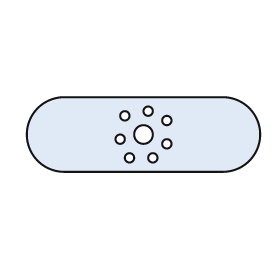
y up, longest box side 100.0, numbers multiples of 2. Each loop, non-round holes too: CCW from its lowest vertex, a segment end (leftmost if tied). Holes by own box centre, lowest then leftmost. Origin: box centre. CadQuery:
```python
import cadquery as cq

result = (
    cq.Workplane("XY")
    .moveTo(-34.0, -16.0)
    .lineTo(34.0, -16.0)
    .threePointArc((50.0, 0.0), (34.0, 16.0))
    .lineTo(-34.0, 16.0)
    .threePointArc((-50.0, 0.0), (-34.0, -16.0))
    .close()
    .moveTo(-6.0, -10.0)
    .circle(2.0)
    .moveTo(4.0, -10.0)
    .circle(2.0)
    .moveTo(10.0, -4.0)
    .circle(2.0)
    .moveTo(-10.0, -2.0)
    .circle(2.0)
    .moveTo(0.0, 0.0)
    .circle(4.0)
    .moveTo(10.0, 6.0)
    .circle(2.0)
    .moveTo(-8.0, 8.0)
    .circle(2.0)
    .moveTo(2.0, 10.0)
    .circle(2.0)
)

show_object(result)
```